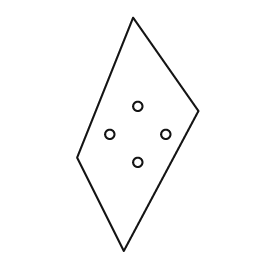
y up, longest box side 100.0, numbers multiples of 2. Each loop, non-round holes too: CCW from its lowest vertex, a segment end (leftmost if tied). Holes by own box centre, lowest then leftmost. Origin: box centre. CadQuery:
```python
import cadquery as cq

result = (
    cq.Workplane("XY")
    .moveTo(-6.0, -50.0)
    .lineTo(26.0, 10.0)
    .lineTo(-2.0, 50.0)
    .lineTo(-26.0, -10.0)
    .close()
    .moveTo(0.0, -12.0)
    .circle(2.0)
    .moveTo(-12.0, 0.0)
    .circle(2.0)
    .moveTo(12.0, 0.0)
    .circle(2.0)
    .moveTo(0.0, 12.0)
    .circle(2.0)
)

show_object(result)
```